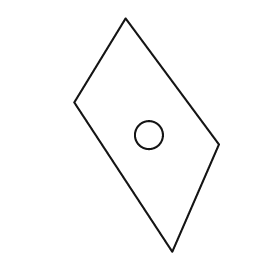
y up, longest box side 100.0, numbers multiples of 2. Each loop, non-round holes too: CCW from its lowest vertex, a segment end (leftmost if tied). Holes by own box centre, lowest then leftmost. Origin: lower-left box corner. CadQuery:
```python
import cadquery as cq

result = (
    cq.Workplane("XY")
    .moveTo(42.0, 0.0)
    .lineTo(62.0, 46.0)
    .lineTo(22.0, 100.0)
    .lineTo(0.0, 64.0)
    .close()
    .moveTo(32.0, 50.0)
    .circle(6.0)
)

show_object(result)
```